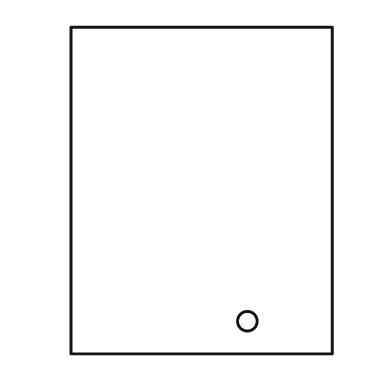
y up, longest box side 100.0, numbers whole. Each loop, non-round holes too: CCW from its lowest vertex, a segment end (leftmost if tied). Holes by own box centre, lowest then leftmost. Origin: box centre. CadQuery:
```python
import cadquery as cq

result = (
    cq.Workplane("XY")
    .moveTo(-40.0, -50.0)
    .lineTo(40.0, -50.0)
    .lineTo(40.0, 50.0)
    .lineTo(-40.0, 50.0)
    .close()
    .moveTo(14.0, -40.0)
    .circle(3.0)
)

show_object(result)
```